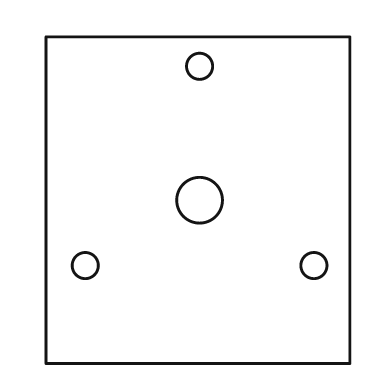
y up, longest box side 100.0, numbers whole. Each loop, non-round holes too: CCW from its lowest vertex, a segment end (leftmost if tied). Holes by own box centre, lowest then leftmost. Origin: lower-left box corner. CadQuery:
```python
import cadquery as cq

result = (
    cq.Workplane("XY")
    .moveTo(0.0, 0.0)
    .lineTo(93.0, 0.0)
    .lineTo(93.0, 100.0)
    .lineTo(0.0, 100.0)
    .close()
    .moveTo(12.0, 30.0)
    .circle(4.0)
    .moveTo(82.0, 30.0)
    .circle(4.0)
    .moveTo(47.0, 50.0)
    .circle(7.0)
    .moveTo(47.0, 91.0)
    .circle(4.0)
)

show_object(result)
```